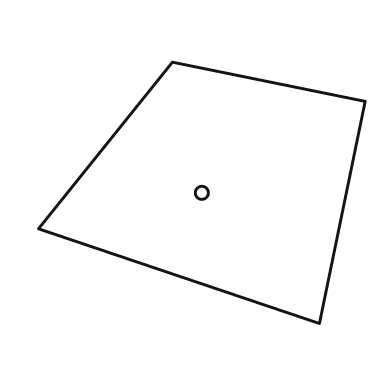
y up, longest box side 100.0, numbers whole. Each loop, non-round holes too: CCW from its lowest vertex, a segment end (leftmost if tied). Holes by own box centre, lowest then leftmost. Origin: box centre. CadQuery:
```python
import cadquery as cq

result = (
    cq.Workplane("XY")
    .moveTo(36.0, -40.0)
    .lineTo(50.0, 28.0)
    .lineTo(-9.0, 40.0)
    .lineTo(-50.0, -11.0)
    .close()
    .moveTo(0.0, 0.0)
    .circle(2.0)
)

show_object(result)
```